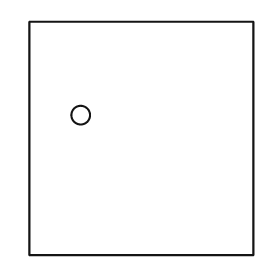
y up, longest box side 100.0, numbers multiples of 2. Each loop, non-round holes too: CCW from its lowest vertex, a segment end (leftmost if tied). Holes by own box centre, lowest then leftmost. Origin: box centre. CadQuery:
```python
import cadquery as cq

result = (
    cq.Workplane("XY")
    .moveTo(-48.0, -50.0)
    .lineTo(48.0, -50.0)
    .lineTo(48.0, 50.0)
    .lineTo(-48.0, 50.0)
    .close()
    .moveTo(-26.0, 10.0)
    .circle(4.0)
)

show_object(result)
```